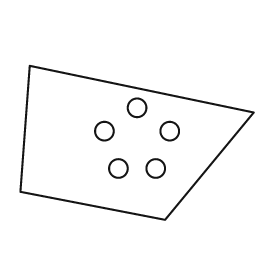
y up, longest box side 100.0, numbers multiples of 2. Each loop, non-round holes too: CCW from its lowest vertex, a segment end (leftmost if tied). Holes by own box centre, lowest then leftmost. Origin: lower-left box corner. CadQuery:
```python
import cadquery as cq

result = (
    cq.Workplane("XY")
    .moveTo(62.0, 0.0)
    .lineTo(100.0, 46.0)
    .lineTo(4.0, 66.0)
    .lineTo(0.0, 12.0)
    .close()
    .moveTo(42.0, 22.0)
    .circle(4.0)
    .moveTo(58.0, 22.0)
    .circle(4.0)
    .moveTo(36.0, 38.0)
    .circle(4.0)
    .moveTo(64.0, 38.0)
    .circle(4.0)
    .moveTo(50.0, 48.0)
    .circle(4.0)
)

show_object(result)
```